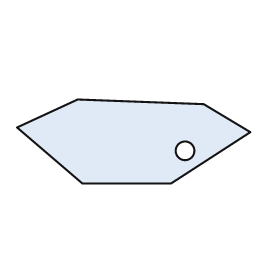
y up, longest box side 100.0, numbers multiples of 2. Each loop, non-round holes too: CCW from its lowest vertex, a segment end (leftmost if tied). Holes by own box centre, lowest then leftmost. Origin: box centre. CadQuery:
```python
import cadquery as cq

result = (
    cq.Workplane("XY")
    .moveTo(-22.0, -18.0)
    .lineTo(16.0, -18.0)
    .lineTo(50.0, 4.0)
    .lineTo(30.0, 16.0)
    .lineTo(-24.0, 18.0)
    .lineTo(-50.0, 6.0)
    .close()
    .moveTo(22.0, -4.0)
    .circle(4.0)
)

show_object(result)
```